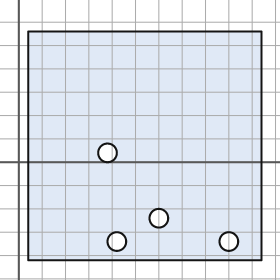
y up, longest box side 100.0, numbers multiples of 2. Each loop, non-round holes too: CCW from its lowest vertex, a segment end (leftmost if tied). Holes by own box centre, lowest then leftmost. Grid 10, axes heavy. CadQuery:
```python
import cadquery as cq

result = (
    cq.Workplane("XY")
    .moveTo(4.0, -42.0)
    .lineTo(104.0, -42.0)
    .lineTo(104.0, 56.0)
    .lineTo(4.0, 56.0)
    .close()
    .moveTo(42.0, -34.0)
    .circle(4.0)
    .moveTo(90.0, -34.0)
    .circle(4.0)
    .moveTo(60.0, -24.0)
    .circle(4.0)
    .moveTo(38.0, 4.0)
    .circle(4.0)
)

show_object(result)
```